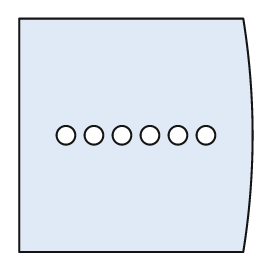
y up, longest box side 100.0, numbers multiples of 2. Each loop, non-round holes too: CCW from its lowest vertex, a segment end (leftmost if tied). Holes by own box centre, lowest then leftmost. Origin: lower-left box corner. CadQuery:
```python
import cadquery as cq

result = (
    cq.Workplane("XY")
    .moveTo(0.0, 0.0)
    .lineTo(96.0, 0.0)
    .threePointArc((100.0, 50.0), (96.0, 100.0))
    .lineTo(0.0, 100.0)
    .close()
    .moveTo(20.0, 50.0)
    .circle(4.0)
    .moveTo(32.0, 50.0)
    .circle(4.0)
    .moveTo(44.0, 50.0)
    .circle(4.0)
    .moveTo(56.0, 50.0)
    .circle(4.0)
    .moveTo(68.0, 50.0)
    .circle(4.0)
    .moveTo(80.0, 50.0)
    .circle(4.0)
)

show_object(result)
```